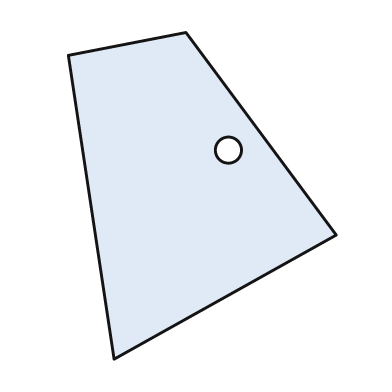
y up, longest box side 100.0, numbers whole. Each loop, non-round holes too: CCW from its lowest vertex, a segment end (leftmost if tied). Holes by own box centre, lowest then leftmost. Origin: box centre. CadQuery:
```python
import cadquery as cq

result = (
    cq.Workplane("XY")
    .moveTo(-27.0, -50.0)
    .lineTo(41.0, -12.0)
    .lineTo(-5.0, 50.0)
    .lineTo(-41.0, 43.0)
    .close()
    .moveTo(8.0, 14.0)
    .circle(4.0)
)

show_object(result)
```